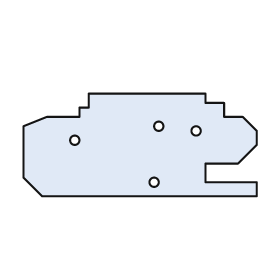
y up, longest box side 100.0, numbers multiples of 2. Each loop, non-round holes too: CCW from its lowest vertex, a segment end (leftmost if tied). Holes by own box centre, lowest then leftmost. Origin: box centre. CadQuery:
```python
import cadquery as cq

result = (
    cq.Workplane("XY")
    .moveTo(-42.0, -22.0)
    .lineTo(50.0, -22.0)
    .lineTo(50.0, -16.0)
    .lineTo(28.0, -16.0)
    .lineTo(28.0, -8.0)
    .lineTo(42.0, -8.0)
    .lineTo(50.0, 0.0)
    .lineTo(50.0, 6.0)
    .lineTo(44.0, 12.0)
    .lineTo(36.0, 12.0)
    .lineTo(36.0, 18.0)
    .lineTo(28.0, 18.0)
    .lineTo(28.0, 22.0)
    .lineTo(-22.0, 22.0)
    .lineTo(-22.0, 16.0)
    .lineTo(-26.0, 16.0)
    .lineTo(-26.0, 12.0)
    .lineTo(-40.0, 12.0)
    .lineTo(-50.0, 8.0)
    .lineTo(-50.0, -14.0)
    .close()
    .moveTo(6.0, -16.0)
    .circle(2.0)
    .moveTo(-28.0, 2.0)
    .circle(2.0)
    .moveTo(24.0, 6.0)
    .circle(2.0)
    .moveTo(8.0, 8.0)
    .circle(2.0)
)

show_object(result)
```